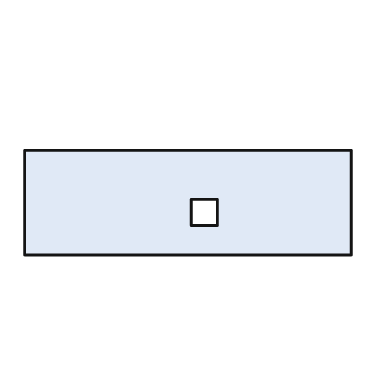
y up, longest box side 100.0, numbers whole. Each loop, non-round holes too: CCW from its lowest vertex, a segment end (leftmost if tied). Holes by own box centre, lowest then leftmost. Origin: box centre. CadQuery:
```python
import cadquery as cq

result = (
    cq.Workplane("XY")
    .moveTo(-50.0, -16.0)
    .lineTo(50.0, -16.0)
    .lineTo(50.0, 16.0)
    .lineTo(-50.0, 16.0)
    .close()
    .moveTo(1.0, -7.0)
    .lineTo(9.0, -7.0)
    .lineTo(9.0, 1.0)
    .lineTo(1.0, 1.0)
    .close()
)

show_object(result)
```